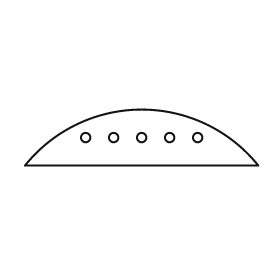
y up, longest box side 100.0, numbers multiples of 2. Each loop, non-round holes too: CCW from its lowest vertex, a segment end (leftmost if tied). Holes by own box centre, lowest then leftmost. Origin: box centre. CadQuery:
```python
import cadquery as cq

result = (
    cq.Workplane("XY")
    .moveTo(-50.0, -12.0)
    .lineTo(50.0, -12.0)
    .threePointArc((0.0, 12.0), (-50.0, -12.0))
    .close()
    .moveTo(-24.0, 0.0)
    .circle(2.0)
    .moveTo(-12.0, 0.0)
    .circle(2.0)
    .moveTo(0.0, 0.0)
    .circle(2.0)
    .moveTo(12.0, 0.0)
    .circle(2.0)
    .moveTo(24.0, 0.0)
    .circle(2.0)
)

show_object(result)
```